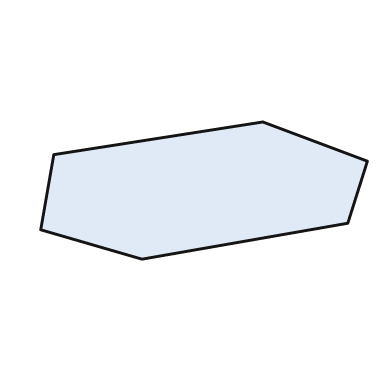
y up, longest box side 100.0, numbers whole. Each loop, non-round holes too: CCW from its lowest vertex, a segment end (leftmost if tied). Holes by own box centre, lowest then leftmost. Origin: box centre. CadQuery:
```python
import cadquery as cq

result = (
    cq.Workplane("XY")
    .moveTo(-19.0, -21.0)
    .lineTo(44.0, -10.0)
    .lineTo(50.0, 9.0)
    .lineTo(18.0, 21.0)
    .lineTo(-46.0, 11.0)
    .lineTo(-50.0, -12.0)
    .close()
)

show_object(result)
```